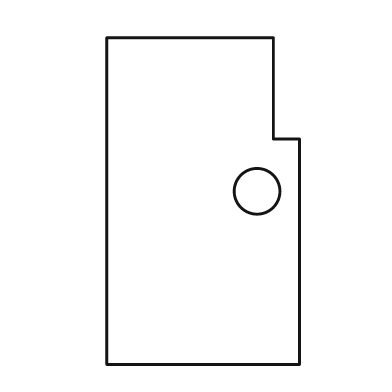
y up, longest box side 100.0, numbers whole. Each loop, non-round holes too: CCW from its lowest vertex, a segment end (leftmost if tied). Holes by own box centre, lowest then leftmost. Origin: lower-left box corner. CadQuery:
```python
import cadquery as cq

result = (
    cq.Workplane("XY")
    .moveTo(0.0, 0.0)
    .lineTo(59.0, 0.0)
    .lineTo(59.0, 69.0)
    .lineTo(51.0, 69.0)
    .lineTo(51.0, 100.0)
    .lineTo(0.0, 100.0)
    .close()
    .moveTo(46.0, 53.0)
    .circle(7.0)
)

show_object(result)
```